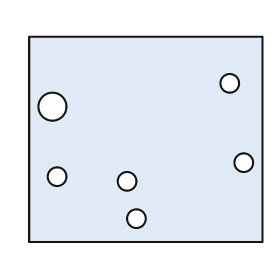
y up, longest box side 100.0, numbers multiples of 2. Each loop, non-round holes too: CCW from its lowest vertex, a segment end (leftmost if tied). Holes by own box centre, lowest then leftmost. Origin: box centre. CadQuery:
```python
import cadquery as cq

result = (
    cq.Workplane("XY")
    .moveTo(-50.0, -44.0)
    .lineTo(50.0, -44.0)
    .lineTo(50.0, 44.0)
    .lineTo(-50.0, 44.0)
    .close()
    .moveTo(-4.0, -34.0)
    .circle(4.0)
    .moveTo(-8.0, -18.0)
    .circle(4.0)
    .moveTo(-38.0, -16.0)
    .circle(4.0)
    .moveTo(42.0, -10.0)
    .circle(4.0)
    .moveTo(-40.0, 14.0)
    .circle(6.0)
    .moveTo(36.0, 24.0)
    .circle(4.0)
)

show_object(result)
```